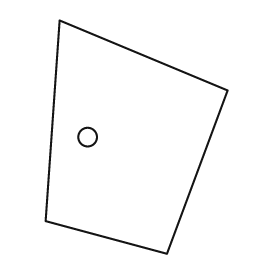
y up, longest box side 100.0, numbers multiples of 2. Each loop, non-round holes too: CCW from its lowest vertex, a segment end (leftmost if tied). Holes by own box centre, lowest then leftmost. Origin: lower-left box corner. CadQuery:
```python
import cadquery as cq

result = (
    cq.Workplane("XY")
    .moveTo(52.0, 0.0)
    .lineTo(78.0, 70.0)
    .lineTo(6.0, 100.0)
    .lineTo(0.0, 14.0)
    .close()
    .moveTo(18.0, 50.0)
    .circle(4.0)
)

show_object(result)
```